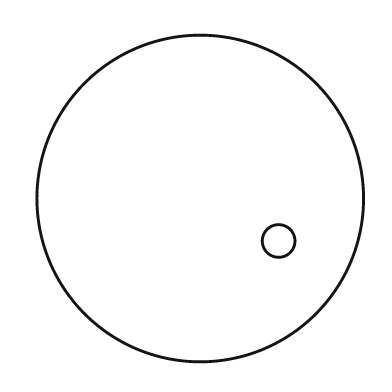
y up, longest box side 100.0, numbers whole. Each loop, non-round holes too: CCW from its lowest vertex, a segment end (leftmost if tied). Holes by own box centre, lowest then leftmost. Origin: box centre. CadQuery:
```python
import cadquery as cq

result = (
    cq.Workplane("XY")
    .moveTo(0.0, 0.0)
    .circle(50.0)
    .moveTo(24.0, -13.0)
    .circle(5.0)
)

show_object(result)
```